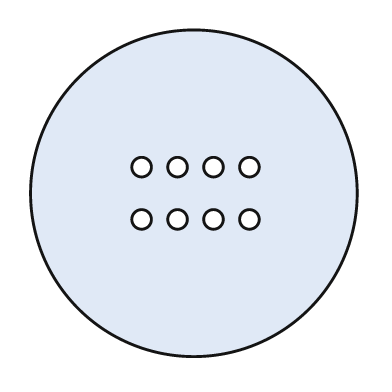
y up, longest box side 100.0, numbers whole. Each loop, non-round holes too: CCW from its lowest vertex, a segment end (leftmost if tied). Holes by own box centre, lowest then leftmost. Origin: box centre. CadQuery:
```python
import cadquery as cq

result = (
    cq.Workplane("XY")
    .moveTo(0.0, 0.0)
    .circle(50.0)
    .moveTo(-16.0, -8.0)
    .circle(3.0)
    .moveTo(-5.0, -8.0)
    .circle(3.0)
    .moveTo(6.0, -8.0)
    .circle(3.0)
    .moveTo(17.0, -8.0)
    .circle(3.0)
    .moveTo(-16.0, 8.0)
    .circle(3.0)
    .moveTo(-5.0, 8.0)
    .circle(3.0)
    .moveTo(6.0, 8.0)
    .circle(3.0)
    .moveTo(17.0, 8.0)
    .circle(3.0)
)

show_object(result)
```